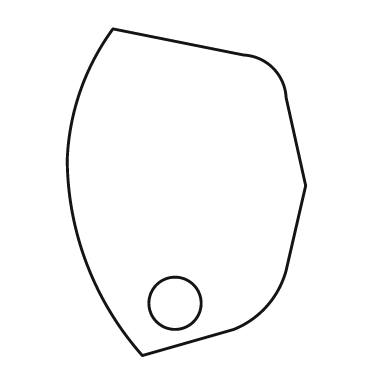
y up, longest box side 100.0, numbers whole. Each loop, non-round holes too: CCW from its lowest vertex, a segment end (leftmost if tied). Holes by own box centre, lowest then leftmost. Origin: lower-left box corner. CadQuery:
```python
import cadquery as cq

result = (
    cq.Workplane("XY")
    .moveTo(23.0, 0.0)
    .lineTo(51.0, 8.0)
    .threePointArc((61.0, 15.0), (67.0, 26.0))
    .lineTo(73.0, 52.0)
    .lineTo(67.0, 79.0)
    .threePointArc((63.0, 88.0), (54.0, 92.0))
    .lineTo(14.0, 100.0)
    .threePointArc((4.0, 81.0), (0.0, 60.0))
    .threePointArc((6.0, 28.0), (23.0, 0.0))
    .close()
    .moveTo(33.0, 16.0)
    .circle(8.0)
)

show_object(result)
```